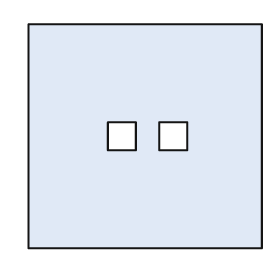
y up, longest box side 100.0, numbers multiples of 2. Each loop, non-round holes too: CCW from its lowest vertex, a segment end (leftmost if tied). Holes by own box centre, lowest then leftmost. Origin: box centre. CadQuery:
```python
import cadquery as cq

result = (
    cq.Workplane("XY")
    .moveTo(-50.0, -48.0)
    .lineTo(50.0, -48.0)
    .lineTo(50.0, 48.0)
    .lineTo(-50.0, 48.0)
    .close()
    .moveTo(-16.0, -6.0)
    .lineTo(-4.0, -6.0)
    .lineTo(-4.0, 6.0)
    .lineTo(-16.0, 6.0)
    .close()
    .moveTo(6.0, -6.0)
    .lineTo(18.0, -6.0)
    .lineTo(18.0, 6.0)
    .lineTo(6.0, 6.0)
    .close()
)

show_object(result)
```